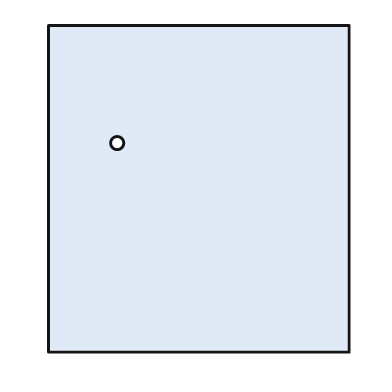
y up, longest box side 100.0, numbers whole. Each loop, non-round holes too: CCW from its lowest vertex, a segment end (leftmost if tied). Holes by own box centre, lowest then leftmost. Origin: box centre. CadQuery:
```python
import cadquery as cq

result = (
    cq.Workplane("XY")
    .moveTo(-46.0, -50.0)
    .lineTo(46.0, -50.0)
    .lineTo(46.0, 50.0)
    .lineTo(-46.0, 50.0)
    .close()
    .moveTo(-25.0, 14.0)
    .circle(2.0)
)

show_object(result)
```